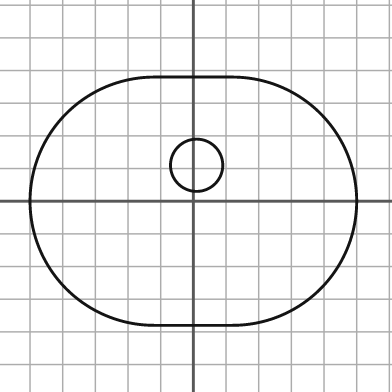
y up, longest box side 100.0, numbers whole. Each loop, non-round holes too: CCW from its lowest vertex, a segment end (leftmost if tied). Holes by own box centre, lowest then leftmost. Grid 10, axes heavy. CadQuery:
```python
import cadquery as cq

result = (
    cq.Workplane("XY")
    .moveTo(-12.0, -38.0)
    .lineTo(12.0, -38.0)
    .threePointArc((50.0, 0.0), (12.0, 38.0))
    .lineTo(-12.0, 38.0)
    .threePointArc((-50.0, 0.0), (-12.0, -38.0))
    .close()
    .moveTo(1.0, 11.0)
    .circle(8.0)
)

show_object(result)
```